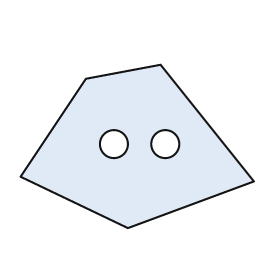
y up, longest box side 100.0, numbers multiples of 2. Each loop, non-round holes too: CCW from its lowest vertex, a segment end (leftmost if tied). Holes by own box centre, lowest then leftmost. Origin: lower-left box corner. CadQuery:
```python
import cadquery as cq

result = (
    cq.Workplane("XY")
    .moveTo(46.0, 0.0)
    .lineTo(100.0, 20.0)
    .lineTo(60.0, 70.0)
    .lineTo(28.0, 64.0)
    .lineTo(0.0, 22.0)
    .close()
    .moveTo(40.0, 36.0)
    .circle(6.0)
    .moveTo(62.0, 36.0)
    .circle(6.0)
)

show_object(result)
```